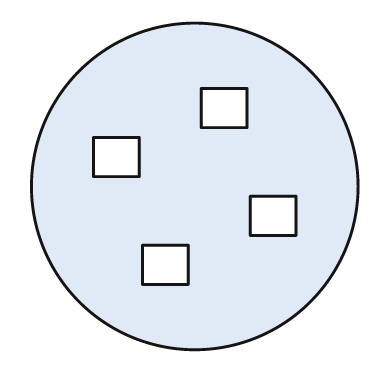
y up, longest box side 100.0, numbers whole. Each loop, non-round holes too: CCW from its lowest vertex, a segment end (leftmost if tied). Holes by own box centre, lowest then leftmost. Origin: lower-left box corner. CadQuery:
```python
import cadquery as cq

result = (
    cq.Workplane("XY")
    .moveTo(50.0, 50.0)
    .circle(50.0)
    .moveTo(34.0, 20.0)
    .lineTo(48.0, 20.0)
    .lineTo(48.0, 32.0)
    .lineTo(34.0, 32.0)
    .close()
    .moveTo(67.0, 35.0)
    .lineTo(81.0, 35.0)
    .lineTo(81.0, 47.0)
    .lineTo(67.0, 47.0)
    .close()
    .moveTo(19.0, 53.0)
    .lineTo(33.0, 53.0)
    .lineTo(33.0, 65.0)
    .lineTo(19.0, 65.0)
    .close()
    .moveTo(52.0, 68.0)
    .lineTo(66.0, 68.0)
    .lineTo(66.0, 80.0)
    .lineTo(52.0, 80.0)
    .close()
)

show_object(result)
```